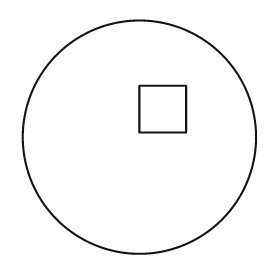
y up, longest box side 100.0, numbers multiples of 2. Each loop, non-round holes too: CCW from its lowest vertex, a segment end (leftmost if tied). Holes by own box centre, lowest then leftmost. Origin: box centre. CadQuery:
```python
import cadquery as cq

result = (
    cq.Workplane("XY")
    .moveTo(0.0, 0.0)
    .circle(50.0)
    .moveTo(0.0, 2.0)
    .lineTo(20.0, 2.0)
    .lineTo(20.0, 22.0)
    .lineTo(0.0, 22.0)
    .close()
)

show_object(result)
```